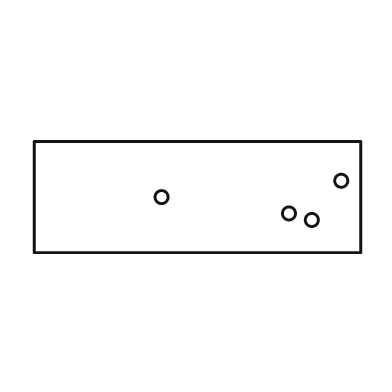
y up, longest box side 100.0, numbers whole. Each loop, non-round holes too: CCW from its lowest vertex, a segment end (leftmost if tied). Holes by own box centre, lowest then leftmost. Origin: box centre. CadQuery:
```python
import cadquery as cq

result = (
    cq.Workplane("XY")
    .moveTo(-50.0, -17.0)
    .lineTo(50.0, -17.0)
    .lineTo(50.0, 17.0)
    .lineTo(-50.0, 17.0)
    .close()
    .moveTo(35.0, -7.0)
    .circle(2.0)
    .moveTo(28.0, -5.0)
    .circle(2.0)
    .moveTo(-11.0, 0.0)
    .circle(2.0)
    .moveTo(44.0, 5.0)
    .circle(2.0)
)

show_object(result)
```